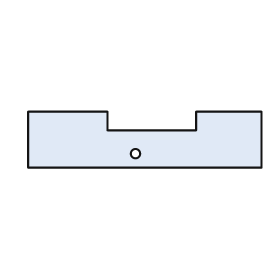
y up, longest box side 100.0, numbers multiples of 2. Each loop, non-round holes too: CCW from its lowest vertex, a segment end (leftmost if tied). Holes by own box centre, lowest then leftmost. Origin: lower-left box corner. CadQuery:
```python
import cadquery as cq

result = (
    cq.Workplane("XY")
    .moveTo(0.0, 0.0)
    .lineTo(100.0, 0.0)
    .lineTo(100.0, 24.0)
    .lineTo(72.0, 24.0)
    .lineTo(72.0, 16.0)
    .lineTo(34.0, 16.0)
    .lineTo(34.0, 24.0)
    .lineTo(0.0, 24.0)
    .close()
    .moveTo(46.0, 6.0)
    .circle(2.0)
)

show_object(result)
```